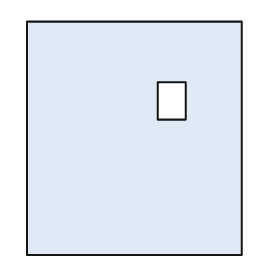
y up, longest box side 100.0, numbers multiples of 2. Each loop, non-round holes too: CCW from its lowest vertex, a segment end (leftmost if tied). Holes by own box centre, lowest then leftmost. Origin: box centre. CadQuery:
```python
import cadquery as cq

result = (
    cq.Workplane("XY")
    .moveTo(-46.0, -50.0)
    .lineTo(46.0, -50.0)
    .lineTo(46.0, 50.0)
    .lineTo(-46.0, 50.0)
    .close()
    .moveTo(10.0, 8.0)
    .lineTo(22.0, 8.0)
    .lineTo(22.0, 24.0)
    .lineTo(10.0, 24.0)
    .close()
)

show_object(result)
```